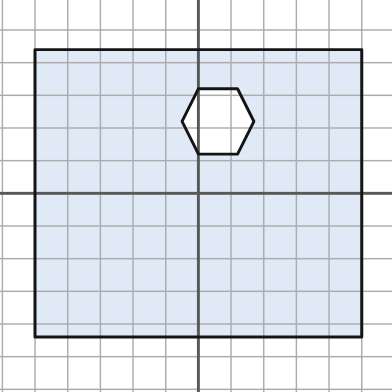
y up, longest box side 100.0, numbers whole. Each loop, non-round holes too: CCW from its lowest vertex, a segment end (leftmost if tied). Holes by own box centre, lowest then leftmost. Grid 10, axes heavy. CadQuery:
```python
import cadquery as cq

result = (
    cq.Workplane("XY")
    .moveTo(-50.0, -44.0)
    .lineTo(50.0, -44.0)
    .lineTo(50.0, 44.0)
    .lineTo(-50.0, 44.0)
    .close()
    .moveTo(0.0, 12.0)
    .lineTo(12.0, 12.0)
    .lineTo(17.0, 22.0)
    .lineTo(12.0, 32.0)
    .lineTo(0.0, 32.0)
    .lineTo(-5.0, 22.0)
    .close()
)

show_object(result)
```